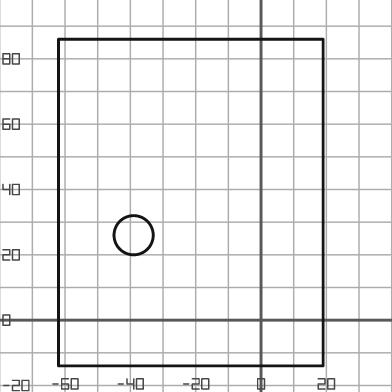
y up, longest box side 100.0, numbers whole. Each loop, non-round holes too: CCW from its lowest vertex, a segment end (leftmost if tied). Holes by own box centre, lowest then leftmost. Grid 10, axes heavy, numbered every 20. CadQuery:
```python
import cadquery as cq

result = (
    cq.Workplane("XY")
    .moveTo(-62.0, -14.0)
    .lineTo(19.0, -14.0)
    .lineTo(19.0, 86.0)
    .lineTo(-62.0, 86.0)
    .close()
    .moveTo(-39.0, 26.0)
    .circle(6.0)
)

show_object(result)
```